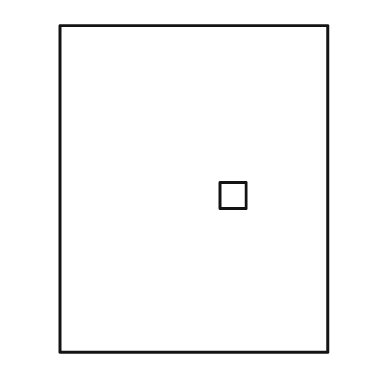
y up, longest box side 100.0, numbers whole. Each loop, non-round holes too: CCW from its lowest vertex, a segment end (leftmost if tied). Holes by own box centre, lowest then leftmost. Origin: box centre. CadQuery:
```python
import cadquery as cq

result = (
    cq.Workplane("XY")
    .moveTo(-41.0, -50.0)
    .lineTo(41.0, -50.0)
    .lineTo(41.0, 50.0)
    .lineTo(-41.0, 50.0)
    .close()
    .moveTo(8.0, -6.0)
    .lineTo(16.0, -6.0)
    .lineTo(16.0, 2.0)
    .lineTo(8.0, 2.0)
    .close()
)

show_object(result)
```